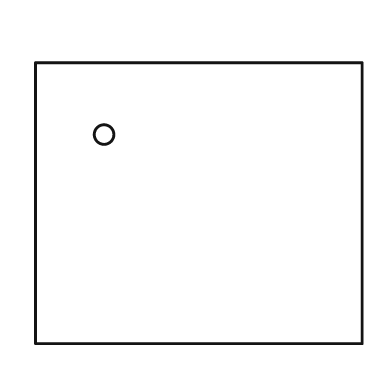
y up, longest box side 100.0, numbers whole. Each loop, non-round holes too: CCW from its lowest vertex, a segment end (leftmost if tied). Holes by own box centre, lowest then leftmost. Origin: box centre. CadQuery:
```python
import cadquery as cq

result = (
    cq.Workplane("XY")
    .moveTo(-50.0, -43.0)
    .lineTo(50.0, -43.0)
    .lineTo(50.0, 43.0)
    .lineTo(-50.0, 43.0)
    .close()
    .moveTo(-29.0, 21.0)
    .circle(3.0)
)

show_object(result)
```